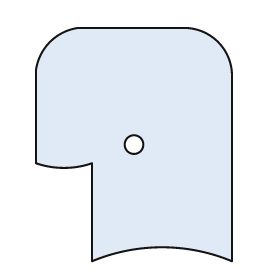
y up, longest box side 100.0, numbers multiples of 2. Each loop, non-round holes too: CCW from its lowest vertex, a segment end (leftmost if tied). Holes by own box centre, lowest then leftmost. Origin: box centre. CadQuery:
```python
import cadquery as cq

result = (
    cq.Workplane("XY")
    .moveTo(-18.0, -50.0)
    .threePointArc((12.0, -44.0), (42.0, -50.0))
    .lineTo(42.0, 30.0)
    .threePointArc((36.0, 44.0), (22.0, 50.0))
    .lineTo(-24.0, 50.0)
    .threePointArc((-36.0, 44.0), (-42.0, 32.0))
    .lineTo(-42.0, -8.0)
    .threePointArc((-30.0, -10.0), (-18.0, -8.0))
    .close()
    .moveTo(0.0, 0.0)
    .circle(4.0)
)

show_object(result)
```